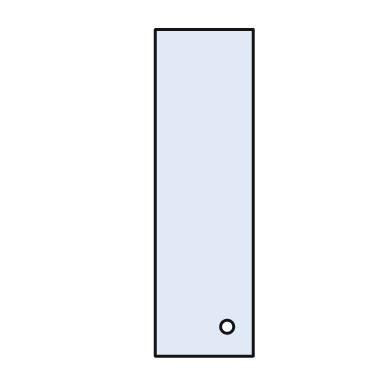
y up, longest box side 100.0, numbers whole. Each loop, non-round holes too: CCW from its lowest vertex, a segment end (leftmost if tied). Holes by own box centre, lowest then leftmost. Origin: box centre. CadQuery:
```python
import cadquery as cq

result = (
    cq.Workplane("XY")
    .moveTo(-15.0, -50.0)
    .lineTo(15.0, -50.0)
    .lineTo(15.0, 50.0)
    .lineTo(-15.0, 50.0)
    .close()
    .moveTo(7.0, -41.0)
    .circle(2.0)
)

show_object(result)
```